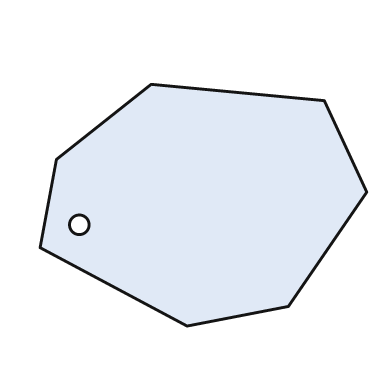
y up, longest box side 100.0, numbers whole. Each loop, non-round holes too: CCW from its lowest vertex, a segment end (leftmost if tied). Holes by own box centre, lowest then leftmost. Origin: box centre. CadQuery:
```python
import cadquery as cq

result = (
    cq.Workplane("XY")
    .moveTo(-5.0, -37.0)
    .lineTo(26.0, -31.0)
    .lineTo(50.0, 4.0)
    .lineTo(37.0, 32.0)
    .lineTo(-16.0, 37.0)
    .lineTo(-45.0, 14.0)
    .lineTo(-50.0, -13.0)
    .close()
    .moveTo(-38.0, -6.0)
    .circle(3.0)
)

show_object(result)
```